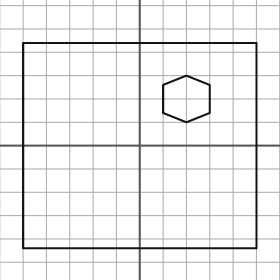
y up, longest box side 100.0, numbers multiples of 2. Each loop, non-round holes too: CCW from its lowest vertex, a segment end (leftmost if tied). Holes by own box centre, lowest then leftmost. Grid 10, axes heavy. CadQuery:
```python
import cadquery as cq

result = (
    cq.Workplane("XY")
    .moveTo(-50.0, -44.0)
    .lineTo(50.0, -44.0)
    .lineTo(50.0, 44.0)
    .lineTo(-50.0, 44.0)
    .close()
    .moveTo(20.0, 10.0)
    .lineTo(30.0, 14.0)
    .lineTo(30.0, 26.0)
    .lineTo(20.0, 30.0)
    .lineTo(10.0, 26.0)
    .lineTo(10.0, 14.0)
    .close()
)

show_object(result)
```